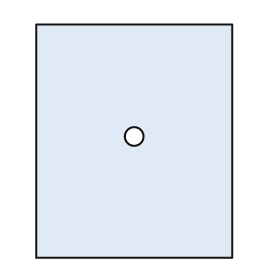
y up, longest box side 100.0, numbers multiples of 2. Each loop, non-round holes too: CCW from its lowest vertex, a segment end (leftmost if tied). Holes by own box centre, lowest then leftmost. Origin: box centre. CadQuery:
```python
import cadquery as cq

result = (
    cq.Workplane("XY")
    .moveTo(-42.0, -50.0)
    .lineTo(42.0, -50.0)
    .lineTo(42.0, 50.0)
    .lineTo(-42.0, 50.0)
    .close()
    .moveTo(0.0, 2.0)
    .circle(4.0)
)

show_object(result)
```